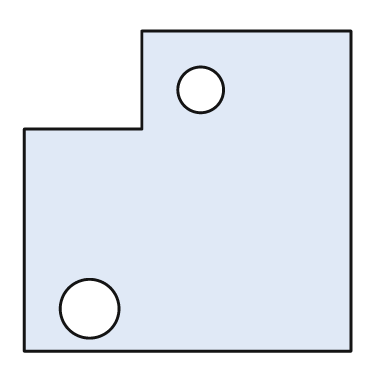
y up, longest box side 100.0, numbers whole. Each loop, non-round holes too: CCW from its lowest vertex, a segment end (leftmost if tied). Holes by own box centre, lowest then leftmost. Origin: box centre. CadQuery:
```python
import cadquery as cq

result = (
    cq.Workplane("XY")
    .moveTo(-50.0, -49.0)
    .lineTo(50.0, -49.0)
    .lineTo(50.0, 49.0)
    .lineTo(-14.0, 49.0)
    .lineTo(-14.0, 19.0)
    .lineTo(-50.0, 19.0)
    .close()
    .moveTo(-30.0, -36.0)
    .circle(9.0)
    .moveTo(4.0, 31.0)
    .circle(7.0)
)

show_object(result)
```